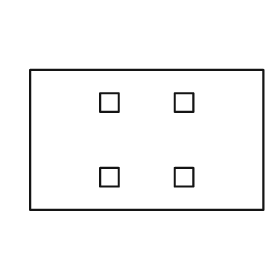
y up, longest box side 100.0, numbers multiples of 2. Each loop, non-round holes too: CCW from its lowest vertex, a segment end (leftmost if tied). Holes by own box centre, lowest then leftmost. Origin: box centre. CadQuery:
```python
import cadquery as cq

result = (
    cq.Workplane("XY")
    .moveTo(-50.0, -30.0)
    .lineTo(50.0, -30.0)
    .lineTo(50.0, 30.0)
    .lineTo(-50.0, 30.0)
    .close()
    .moveTo(-20.0, -20.0)
    .lineTo(-12.0, -20.0)
    .lineTo(-12.0, -12.0)
    .lineTo(-20.0, -12.0)
    .close()
    .moveTo(12.0, -20.0)
    .lineTo(20.0, -20.0)
    .lineTo(20.0, -12.0)
    .lineTo(12.0, -12.0)
    .close()
    .moveTo(-20.0, 12.0)
    .lineTo(-12.0, 12.0)
    .lineTo(-12.0, 20.0)
    .lineTo(-20.0, 20.0)
    .close()
    .moveTo(12.0, 12.0)
    .lineTo(20.0, 12.0)
    .lineTo(20.0, 20.0)
    .lineTo(12.0, 20.0)
    .close()
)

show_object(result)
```